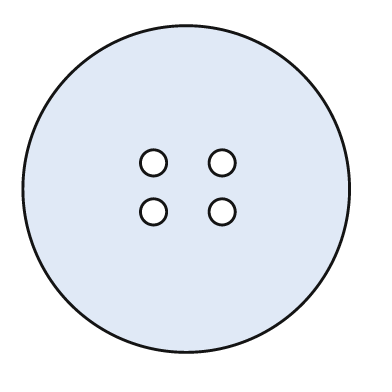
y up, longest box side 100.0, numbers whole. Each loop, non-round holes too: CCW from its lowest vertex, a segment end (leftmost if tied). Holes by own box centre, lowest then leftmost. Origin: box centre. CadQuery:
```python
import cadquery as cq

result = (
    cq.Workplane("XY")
    .moveTo(0.0, 0.0)
    .circle(50.0)
    .moveTo(-10.0, -7.0)
    .circle(4.0)
    .moveTo(11.0, -7.0)
    .circle(4.0)
    .moveTo(-10.0, 8.0)
    .circle(4.0)
    .moveTo(11.0, 8.0)
    .circle(4.0)
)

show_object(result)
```